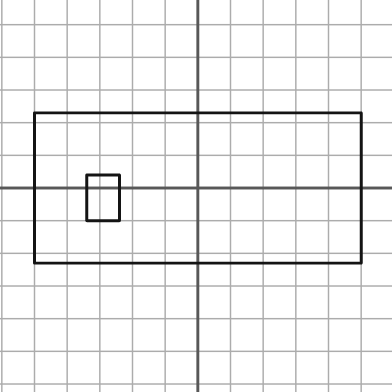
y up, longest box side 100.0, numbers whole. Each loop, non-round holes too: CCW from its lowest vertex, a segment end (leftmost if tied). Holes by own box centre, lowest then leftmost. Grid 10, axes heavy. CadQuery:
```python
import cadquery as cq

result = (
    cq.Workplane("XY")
    .moveTo(-50.0, -23.0)
    .lineTo(50.0, -23.0)
    .lineTo(50.0, 23.0)
    .lineTo(-50.0, 23.0)
    .close()
    .moveTo(-34.0, -10.0)
    .lineTo(-24.0, -10.0)
    .lineTo(-24.0, 4.0)
    .lineTo(-34.0, 4.0)
    .close()
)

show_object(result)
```